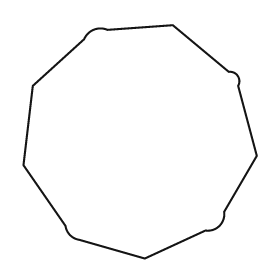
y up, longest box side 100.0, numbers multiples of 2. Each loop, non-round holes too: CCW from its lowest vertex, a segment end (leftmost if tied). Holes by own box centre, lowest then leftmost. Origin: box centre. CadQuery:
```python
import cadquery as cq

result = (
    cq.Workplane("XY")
    .moveTo(2.0, -50.0)
    .lineTo(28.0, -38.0)
    .threePointArc((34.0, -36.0), (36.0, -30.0))
    .lineTo(50.0, -6.0)
    .lineTo(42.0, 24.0)
    .threePointArc((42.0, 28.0), (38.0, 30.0))
    .lineTo(14.0, 50.0)
    .lineTo(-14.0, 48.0)
    .threePointArc((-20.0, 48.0), (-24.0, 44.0))
    .lineTo(-46.0, 24.0)
    .lineTo(-50.0, -10.0)
    .lineTo(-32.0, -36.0)
    .threePointArc((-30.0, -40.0), (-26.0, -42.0))
    .close()
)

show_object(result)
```